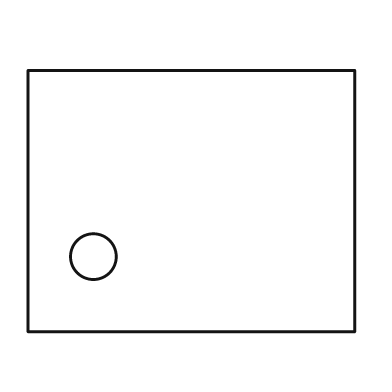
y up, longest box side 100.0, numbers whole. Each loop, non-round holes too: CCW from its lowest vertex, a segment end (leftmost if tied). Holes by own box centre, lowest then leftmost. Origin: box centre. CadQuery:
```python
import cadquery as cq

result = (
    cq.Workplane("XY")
    .moveTo(-50.0, -40.0)
    .lineTo(50.0, -40.0)
    .lineTo(50.0, 40.0)
    .lineTo(-50.0, 40.0)
    .close()
    .moveTo(-30.0, -17.0)
    .circle(7.0)
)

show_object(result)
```